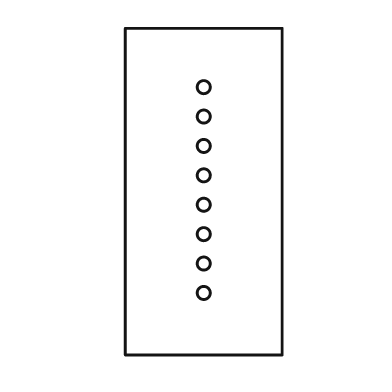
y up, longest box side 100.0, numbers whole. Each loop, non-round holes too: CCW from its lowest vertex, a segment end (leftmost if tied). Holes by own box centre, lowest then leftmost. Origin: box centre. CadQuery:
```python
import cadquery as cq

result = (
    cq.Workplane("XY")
    .moveTo(-24.0, -50.0)
    .lineTo(24.0, -50.0)
    .lineTo(24.0, 50.0)
    .lineTo(-24.0, 50.0)
    .close()
    .moveTo(0.0, -31.0)
    .circle(2.0)
    .moveTo(0.0, -22.0)
    .circle(2.0)
    .moveTo(0.0, -13.0)
    .circle(2.0)
    .moveTo(0.0, -4.0)
    .circle(2.0)
    .moveTo(0.0, 5.0)
    .circle(2.0)
    .moveTo(0.0, 14.0)
    .circle(2.0)
    .moveTo(0.0, 23.0)
    .circle(2.0)
    .moveTo(0.0, 32.0)
    .circle(2.0)
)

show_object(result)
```